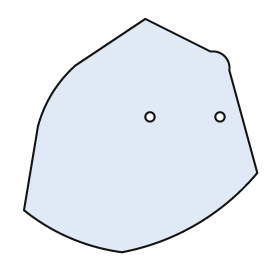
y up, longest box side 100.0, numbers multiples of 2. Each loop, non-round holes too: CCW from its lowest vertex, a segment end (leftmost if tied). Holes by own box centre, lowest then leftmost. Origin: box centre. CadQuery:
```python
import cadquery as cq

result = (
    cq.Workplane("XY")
    .moveTo(-8.0, -50.0)
    .threePointArc((24.0, -38.0), (50.0, -16.0))
    .lineTo(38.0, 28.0)
    .threePointArc((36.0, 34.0), (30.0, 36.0))
    .lineTo(2.0, 50.0)
    .lineTo(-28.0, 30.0)
    .threePointArc((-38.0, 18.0), (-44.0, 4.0))
    .lineTo(-50.0, -32.0)
    .threePointArc((-30.0, -44.0), (-8.0, -50.0))
    .close()
    .moveTo(4.0, 8.0)
    .circle(2.0)
    .moveTo(34.0, 8.0)
    .circle(2.0)
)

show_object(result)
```